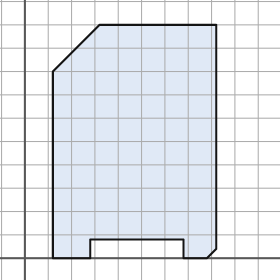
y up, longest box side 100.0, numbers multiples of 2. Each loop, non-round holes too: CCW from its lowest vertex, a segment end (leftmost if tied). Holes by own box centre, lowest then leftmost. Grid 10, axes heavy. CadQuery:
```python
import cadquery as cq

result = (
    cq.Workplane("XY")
    .moveTo(12.0, 0.0)
    .lineTo(28.0, 0.0)
    .lineTo(28.0, 8.0)
    .lineTo(68.0, 8.0)
    .lineTo(68.0, 0.0)
    .lineTo(78.0, 0.0)
    .lineTo(82.0, 4.0)
    .lineTo(82.0, 100.0)
    .lineTo(32.0, 100.0)
    .lineTo(12.0, 80.0)
    .close()
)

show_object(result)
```